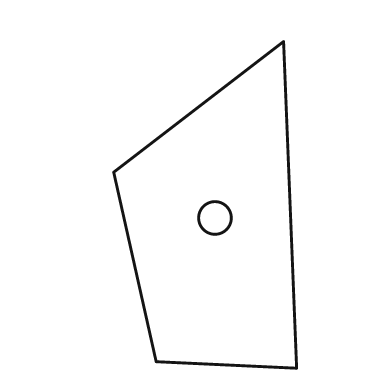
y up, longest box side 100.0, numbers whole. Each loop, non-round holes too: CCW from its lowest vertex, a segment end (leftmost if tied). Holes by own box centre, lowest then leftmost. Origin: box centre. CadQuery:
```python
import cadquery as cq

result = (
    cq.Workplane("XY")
    .moveTo(28.0, -50.0)
    .lineTo(24.0, 50.0)
    .lineTo(-28.0, 10.0)
    .lineTo(-15.0, -48.0)
    .close()
    .moveTo(3.0, -4.0)
    .circle(5.0)
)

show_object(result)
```